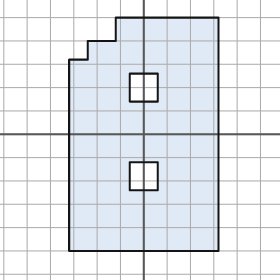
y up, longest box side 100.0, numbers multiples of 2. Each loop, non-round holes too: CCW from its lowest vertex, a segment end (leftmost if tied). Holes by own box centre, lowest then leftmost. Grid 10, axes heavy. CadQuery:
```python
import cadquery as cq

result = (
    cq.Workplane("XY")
    .moveTo(-32.0, -50.0)
    .lineTo(32.0, -50.0)
    .lineTo(32.0, 50.0)
    .lineTo(-12.0, 50.0)
    .lineTo(-12.0, 40.0)
    .lineTo(-24.0, 40.0)
    .lineTo(-24.0, 32.0)
    .lineTo(-32.0, 32.0)
    .close()
    .moveTo(-6.0, -24.0)
    .lineTo(6.0, -24.0)
    .lineTo(6.0, -12.0)
    .lineTo(-6.0, -12.0)
    .close()
    .moveTo(-6.0, 14.0)
    .lineTo(6.0, 14.0)
    .lineTo(6.0, 26.0)
    .lineTo(-6.0, 26.0)
    .close()
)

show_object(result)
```